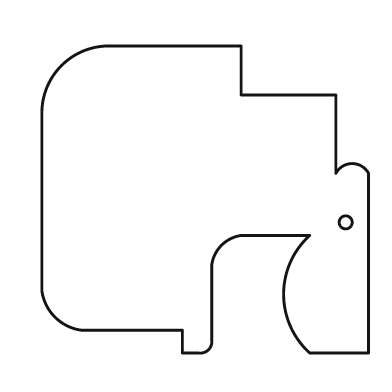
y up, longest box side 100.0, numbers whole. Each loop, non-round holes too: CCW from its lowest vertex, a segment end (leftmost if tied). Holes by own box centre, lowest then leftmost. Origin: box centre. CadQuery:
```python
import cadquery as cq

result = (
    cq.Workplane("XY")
    .moveTo(-7.0, -47.0)
    .lineTo(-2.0, -47.0)
    .threePointArc((1.0, -46.0), (2.0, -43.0))
    .lineTo(2.0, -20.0)
    .threePointArc((5.0, -14.0), (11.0, -11.0))
    .lineTo(32.0, -11.0)
    .threePointArc((24.0, -29.0), (32.0, -47.0))
    .lineTo(50.0, -47.0)
    .lineTo(50.0, 8.0)
    .threePointArc((45.0, 11.0), (40.0, 8.0))
    .lineTo(40.0, 32.0)
    .lineTo(11.0, 32.0)
    .lineTo(11.0, 47.0)
    .lineTo(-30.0, 47.0)
    .threePointArc((-44.0, 41.0), (-50.0, 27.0))
    .lineTo(-50.0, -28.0)
    .threePointArc((-46.0, -36.0), (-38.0, -40.0))
    .lineTo(-7.0, -40.0)
    .close()
    .moveTo(43.0, -7.0)
    .circle(2.0)
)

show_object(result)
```